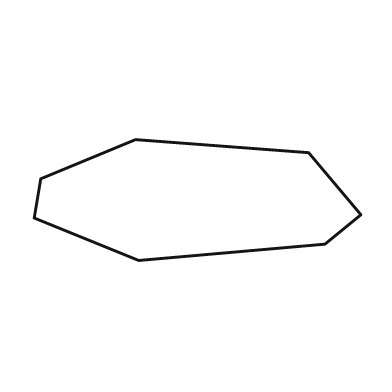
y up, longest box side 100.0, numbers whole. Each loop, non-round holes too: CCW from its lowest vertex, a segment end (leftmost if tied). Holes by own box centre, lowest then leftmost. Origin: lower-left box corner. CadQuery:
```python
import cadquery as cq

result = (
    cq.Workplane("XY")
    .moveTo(32.0, 0.0)
    .lineTo(89.0, 5.0)
    .lineTo(100.0, 14.0)
    .lineTo(84.0, 33.0)
    .lineTo(31.0, 37.0)
    .lineTo(2.0, 25.0)
    .lineTo(0.0, 13.0)
    .close()
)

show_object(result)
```